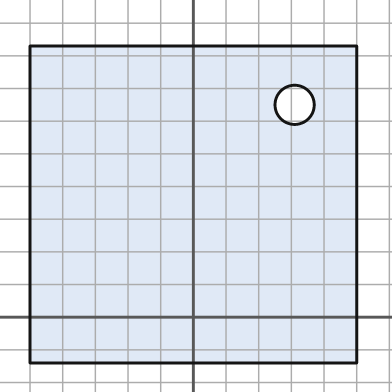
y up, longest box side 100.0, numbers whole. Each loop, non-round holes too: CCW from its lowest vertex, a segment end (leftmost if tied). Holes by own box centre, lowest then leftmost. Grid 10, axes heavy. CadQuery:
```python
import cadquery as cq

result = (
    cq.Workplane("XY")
    .moveTo(-50.0, -14.0)
    .lineTo(50.0, -14.0)
    .lineTo(50.0, 83.0)
    .lineTo(-50.0, 83.0)
    .close()
    .moveTo(31.0, 65.0)
    .circle(6.0)
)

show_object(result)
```